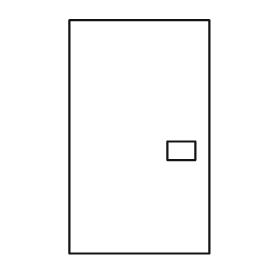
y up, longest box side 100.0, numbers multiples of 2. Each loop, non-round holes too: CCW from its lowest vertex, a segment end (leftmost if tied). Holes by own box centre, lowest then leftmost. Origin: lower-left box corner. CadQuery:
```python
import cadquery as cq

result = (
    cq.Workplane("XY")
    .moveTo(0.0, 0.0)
    .lineTo(60.0, 0.0)
    .lineTo(60.0, 100.0)
    .lineTo(0.0, 100.0)
    .close()
    .moveTo(42.0, 40.0)
    .lineTo(54.0, 40.0)
    .lineTo(54.0, 48.0)
    .lineTo(42.0, 48.0)
    .close()
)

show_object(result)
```